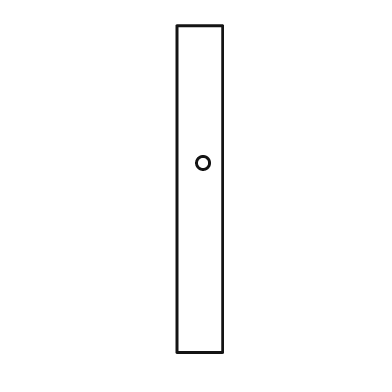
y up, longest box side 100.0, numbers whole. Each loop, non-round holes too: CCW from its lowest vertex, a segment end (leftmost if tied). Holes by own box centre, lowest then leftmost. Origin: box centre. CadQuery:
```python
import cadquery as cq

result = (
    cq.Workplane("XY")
    .moveTo(-7.0, -50.0)
    .lineTo(7.0, -50.0)
    .lineTo(7.0, 50.0)
    .lineTo(-7.0, 50.0)
    .close()
    .moveTo(1.0, 8.0)
    .circle(2.0)
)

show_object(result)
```